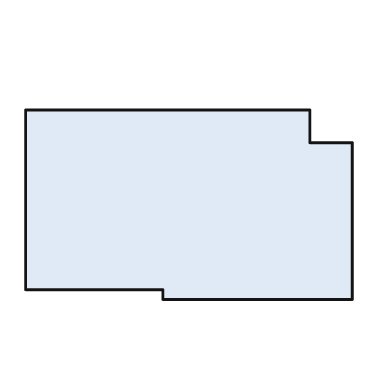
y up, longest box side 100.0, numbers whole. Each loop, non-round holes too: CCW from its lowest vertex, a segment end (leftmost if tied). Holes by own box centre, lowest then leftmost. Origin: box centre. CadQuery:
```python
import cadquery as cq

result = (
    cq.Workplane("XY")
    .moveTo(-8.0, -29.0)
    .lineTo(50.0, -29.0)
    .lineTo(50.0, 19.0)
    .lineTo(37.0, 19.0)
    .lineTo(37.0, 29.0)
    .lineTo(-50.0, 29.0)
    .lineTo(-50.0, -26.0)
    .lineTo(-8.0, -26.0)
    .close()
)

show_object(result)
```